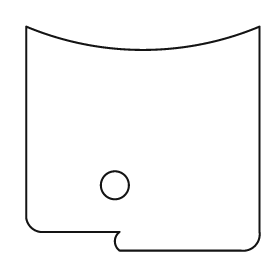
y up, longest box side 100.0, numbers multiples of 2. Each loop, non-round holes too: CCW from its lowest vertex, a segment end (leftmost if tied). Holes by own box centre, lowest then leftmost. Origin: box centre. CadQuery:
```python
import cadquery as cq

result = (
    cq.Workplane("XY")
    .moveTo(-10.0, -48.0)
    .lineTo(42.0, -48.0)
    .threePointArc((48.0, -46.0), (50.0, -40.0))
    .lineTo(50.0, 48.0)
    .threePointArc((0.0, 38.0), (-50.0, 48.0))
    .lineTo(-50.0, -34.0)
    .threePointArc((-48.0, -38.0), (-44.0, -40.0))
    .lineTo(-10.0, -40.0)
    .threePointArc((-12.0, -44.0), (-10.0, -48.0))
    .close()
    .moveTo(-12.0, -20.0)
    .circle(6.0)
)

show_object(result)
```